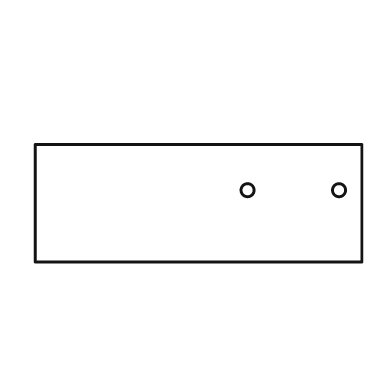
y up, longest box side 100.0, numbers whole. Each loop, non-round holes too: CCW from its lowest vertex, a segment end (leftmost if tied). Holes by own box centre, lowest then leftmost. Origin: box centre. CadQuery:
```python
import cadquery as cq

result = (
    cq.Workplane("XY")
    .moveTo(-50.0, -18.0)
    .lineTo(50.0, -18.0)
    .lineTo(50.0, 18.0)
    .lineTo(-50.0, 18.0)
    .close()
    .moveTo(15.0, 4.0)
    .circle(2.0)
    .moveTo(43.0, 4.0)
    .circle(2.0)
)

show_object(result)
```